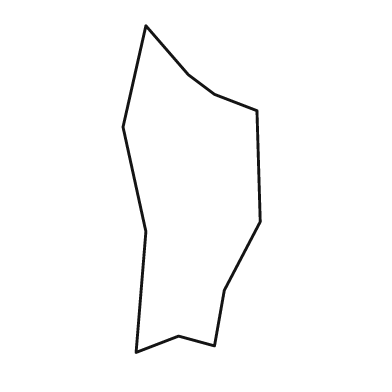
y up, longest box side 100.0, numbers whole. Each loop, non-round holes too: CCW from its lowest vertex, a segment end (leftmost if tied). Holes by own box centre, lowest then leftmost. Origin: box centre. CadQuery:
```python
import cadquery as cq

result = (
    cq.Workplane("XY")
    .moveTo(-17.0, -50.0)
    .lineTo(-4.0, -45.0)
    .lineTo(7.0, -48.0)
    .lineTo(10.0, -31.0)
    .lineTo(21.0, -10.0)
    .lineTo(20.0, 24.0)
    .lineTo(7.0, 29.0)
    .lineTo(-1.0, 35.0)
    .lineTo(-14.0, 50.0)
    .lineTo(-21.0, 19.0)
    .lineTo(-14.0, -13.0)
    .close()
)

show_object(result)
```